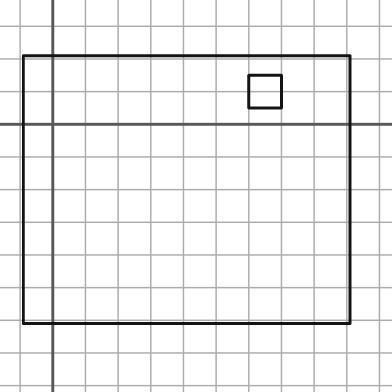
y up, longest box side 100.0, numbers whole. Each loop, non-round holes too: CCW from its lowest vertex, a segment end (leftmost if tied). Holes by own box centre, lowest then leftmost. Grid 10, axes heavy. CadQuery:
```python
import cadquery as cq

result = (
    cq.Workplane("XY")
    .moveTo(-9.0, -61.0)
    .lineTo(91.0, -61.0)
    .lineTo(91.0, 21.0)
    .lineTo(-9.0, 21.0)
    .close()
    .moveTo(60.0, 5.0)
    .lineTo(70.0, 5.0)
    .lineTo(70.0, 15.0)
    .lineTo(60.0, 15.0)
    .close()
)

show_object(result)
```